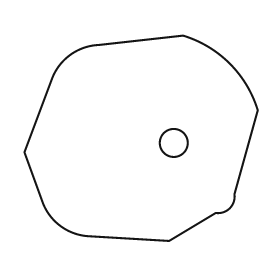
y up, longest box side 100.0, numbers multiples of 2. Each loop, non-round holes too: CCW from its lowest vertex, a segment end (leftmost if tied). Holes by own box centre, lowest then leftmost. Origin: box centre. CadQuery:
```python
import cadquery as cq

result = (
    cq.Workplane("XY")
    .moveTo(12.0, -44.0)
    .lineTo(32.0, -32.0)
    .threePointArc((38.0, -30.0), (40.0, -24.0))
    .lineTo(50.0, 12.0)
    .threePointArc((38.0, 32.0), (18.0, 44.0))
    .lineTo(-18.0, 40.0)
    .threePointArc((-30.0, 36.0), (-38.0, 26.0))
    .lineTo(-50.0, -6.0)
    .lineTo(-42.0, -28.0)
    .threePointArc((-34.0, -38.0), (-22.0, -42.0))
    .close()
    .moveTo(14.0, -2.0)
    .circle(6.0)
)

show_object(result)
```